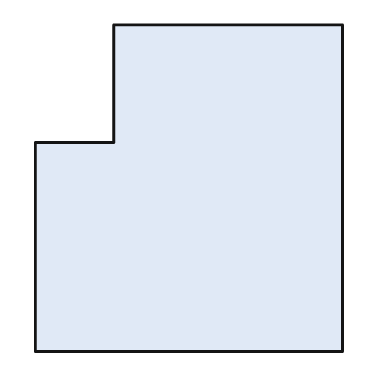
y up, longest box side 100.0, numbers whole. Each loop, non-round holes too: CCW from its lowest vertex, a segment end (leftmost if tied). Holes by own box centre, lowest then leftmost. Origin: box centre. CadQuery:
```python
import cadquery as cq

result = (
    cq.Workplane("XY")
    .moveTo(-47.0, -50.0)
    .lineTo(47.0, -50.0)
    .lineTo(47.0, 50.0)
    .lineTo(-23.0, 50.0)
    .lineTo(-23.0, 14.0)
    .lineTo(-47.0, 14.0)
    .close()
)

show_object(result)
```